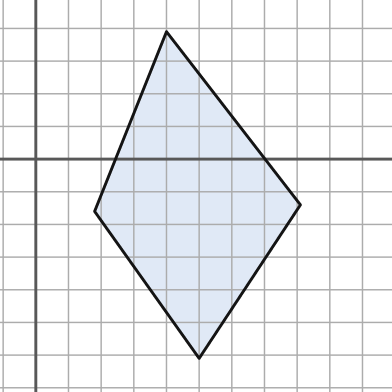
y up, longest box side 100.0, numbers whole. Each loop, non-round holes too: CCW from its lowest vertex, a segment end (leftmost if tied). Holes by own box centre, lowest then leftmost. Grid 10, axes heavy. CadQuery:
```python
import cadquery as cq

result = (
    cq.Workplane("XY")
    .moveTo(50.0, -61.0)
    .lineTo(81.0, -14.0)
    .lineTo(40.0, 39.0)
    .lineTo(18.0, -16.0)
    .close()
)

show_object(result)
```